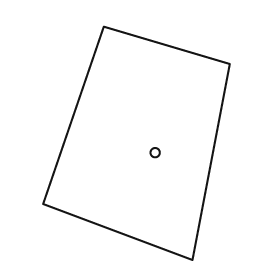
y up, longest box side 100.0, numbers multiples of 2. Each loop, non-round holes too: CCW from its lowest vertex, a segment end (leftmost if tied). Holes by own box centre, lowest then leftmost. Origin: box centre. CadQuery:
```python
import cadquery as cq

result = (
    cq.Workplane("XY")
    .moveTo(24.0, -50.0)
    .lineTo(40.0, 34.0)
    .lineTo(-14.0, 50.0)
    .lineTo(-40.0, -26.0)
    .close()
    .moveTo(8.0, -4.0)
    .circle(2.0)
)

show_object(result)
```